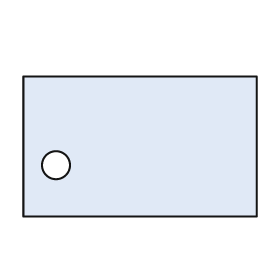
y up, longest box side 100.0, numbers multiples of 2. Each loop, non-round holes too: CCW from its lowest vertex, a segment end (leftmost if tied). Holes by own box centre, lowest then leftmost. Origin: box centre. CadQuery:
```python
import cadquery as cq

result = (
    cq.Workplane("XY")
    .moveTo(-50.0, -30.0)
    .lineTo(50.0, -30.0)
    .lineTo(50.0, 30.0)
    .lineTo(-50.0, 30.0)
    .close()
    .moveTo(-36.0, -8.0)
    .circle(6.0)
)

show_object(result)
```